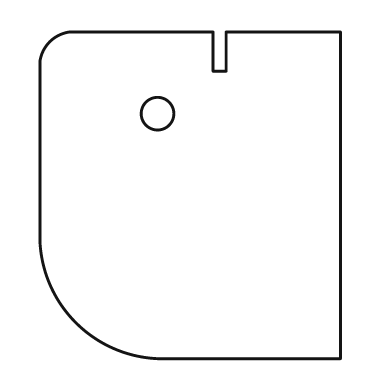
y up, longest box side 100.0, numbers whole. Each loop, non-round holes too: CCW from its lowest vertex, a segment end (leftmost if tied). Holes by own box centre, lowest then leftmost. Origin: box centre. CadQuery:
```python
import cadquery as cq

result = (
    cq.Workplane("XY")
    .moveTo(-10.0, -50.0)
    .lineTo(46.0, -50.0)
    .lineTo(46.0, 50.0)
    .lineTo(11.0, 50.0)
    .lineTo(11.0, 38.0)
    .lineTo(7.0, 38.0)
    .lineTo(7.0, 50.0)
    .lineTo(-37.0, 50.0)
    .threePointArc((-43.0, 47.0), (-46.0, 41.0))
    .lineTo(-46.0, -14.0)
    .threePointArc((-35.0, -39.0), (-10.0, -50.0))
    .close()
    .moveTo(-10.0, 25.0)
    .circle(5.0)
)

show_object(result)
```